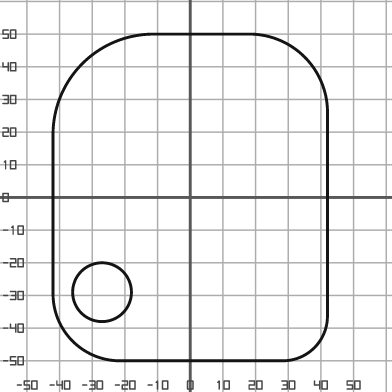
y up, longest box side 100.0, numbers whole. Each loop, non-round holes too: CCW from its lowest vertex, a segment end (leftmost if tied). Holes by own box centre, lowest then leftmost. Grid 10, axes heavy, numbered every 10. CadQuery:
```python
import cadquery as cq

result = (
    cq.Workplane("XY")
    .moveTo(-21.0, -50.0)
    .lineTo(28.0, -50.0)
    .threePointArc((38.0, -46.0), (42.0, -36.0))
    .lineTo(42.0, 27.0)
    .threePointArc((35.0, 43.0), (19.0, 50.0))
    .lineTo(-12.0, 50.0)
    .threePointArc((-33.0, 41.0), (-42.0, 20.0))
    .lineTo(-42.0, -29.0)
    .threePointArc((-36.0, -44.0), (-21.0, -50.0))
    .close()
    .moveTo(-27.0, -29.0)
    .circle(9.0)
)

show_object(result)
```